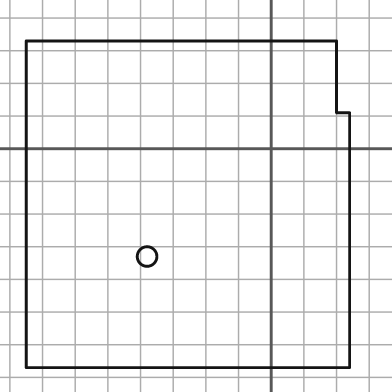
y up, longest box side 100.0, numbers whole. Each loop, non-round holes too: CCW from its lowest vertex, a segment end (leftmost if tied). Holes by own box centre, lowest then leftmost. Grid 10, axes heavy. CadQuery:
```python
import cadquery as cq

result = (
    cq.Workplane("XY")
    .moveTo(-75.0, -67.0)
    .lineTo(24.0, -67.0)
    .lineTo(24.0, 11.0)
    .lineTo(20.0, 11.0)
    .lineTo(20.0, 33.0)
    .lineTo(-75.0, 33.0)
    .close()
    .moveTo(-38.0, -33.0)
    .circle(3.0)
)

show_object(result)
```